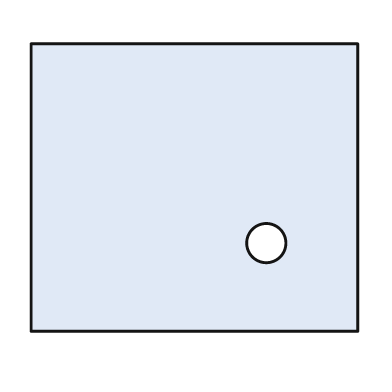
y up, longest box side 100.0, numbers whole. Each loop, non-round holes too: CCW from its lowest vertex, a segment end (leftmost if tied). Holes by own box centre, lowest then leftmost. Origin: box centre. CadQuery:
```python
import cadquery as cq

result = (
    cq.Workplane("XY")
    .moveTo(-50.0, -44.0)
    .lineTo(50.0, -44.0)
    .lineTo(50.0, 44.0)
    .lineTo(-50.0, 44.0)
    .close()
    .moveTo(22.0, -17.0)
    .circle(6.0)
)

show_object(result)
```